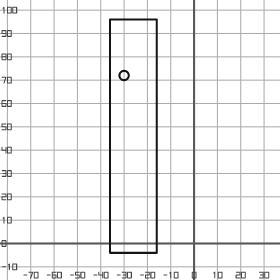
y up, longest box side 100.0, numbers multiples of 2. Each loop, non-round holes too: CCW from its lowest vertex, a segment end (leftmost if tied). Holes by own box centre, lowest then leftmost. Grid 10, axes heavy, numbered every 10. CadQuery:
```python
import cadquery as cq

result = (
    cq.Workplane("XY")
    .moveTo(-36.0, -4.0)
    .lineTo(-16.0, -4.0)
    .lineTo(-16.0, 96.0)
    .lineTo(-36.0, 96.0)
    .close()
    .moveTo(-30.0, 72.0)
    .circle(2.0)
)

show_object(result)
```